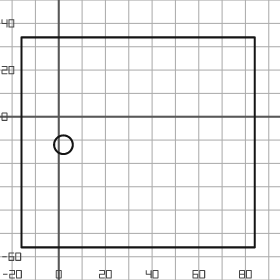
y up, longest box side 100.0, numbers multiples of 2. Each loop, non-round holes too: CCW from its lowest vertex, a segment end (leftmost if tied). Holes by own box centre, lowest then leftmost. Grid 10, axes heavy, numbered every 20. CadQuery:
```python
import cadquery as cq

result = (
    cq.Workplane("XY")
    .moveTo(-16.0, -56.0)
    .lineTo(84.0, -56.0)
    .lineTo(84.0, 34.0)
    .lineTo(-16.0, 34.0)
    .close()
    .moveTo(2.0, -12.0)
    .circle(4.0)
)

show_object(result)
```